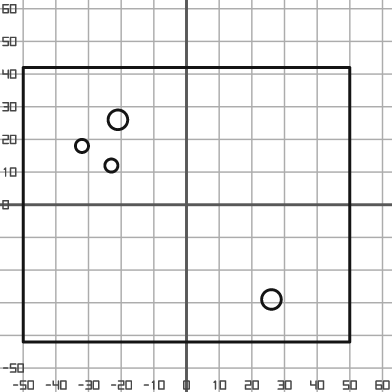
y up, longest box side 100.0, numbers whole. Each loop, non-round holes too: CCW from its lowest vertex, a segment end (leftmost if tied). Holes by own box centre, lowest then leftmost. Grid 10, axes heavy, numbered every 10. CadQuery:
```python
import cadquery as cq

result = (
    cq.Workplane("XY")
    .moveTo(-50.0, -42.0)
    .lineTo(50.0, -42.0)
    .lineTo(50.0, 42.0)
    .lineTo(-50.0, 42.0)
    .close()
    .moveTo(26.0, -29.0)
    .circle(3.0)
    .moveTo(-23.0, 12.0)
    .circle(2.0)
    .moveTo(-32.0, 18.0)
    .circle(2.0)
    .moveTo(-21.0, 26.0)
    .circle(3.0)
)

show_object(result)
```